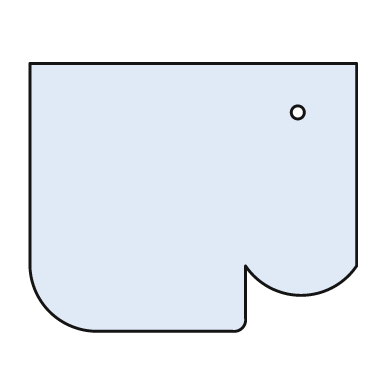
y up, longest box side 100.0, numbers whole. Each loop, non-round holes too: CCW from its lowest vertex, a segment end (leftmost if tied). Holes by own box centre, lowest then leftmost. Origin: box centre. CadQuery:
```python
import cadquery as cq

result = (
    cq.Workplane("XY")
    .moveTo(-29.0, -41.0)
    .lineTo(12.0, -41.0)
    .threePointArc((15.0, -40.0), (16.0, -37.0))
    .lineTo(16.0, -21.0)
    .threePointArc((33.0, -30.0), (50.0, -21.0))
    .lineTo(50.0, 41.0)
    .lineTo(-50.0, 41.0)
    .lineTo(-50.0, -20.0)
    .threePointArc((-44.0, -35.0), (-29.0, -41.0))
    .close()
    .moveTo(32.0, 26.0)
    .circle(2.0)
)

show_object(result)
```